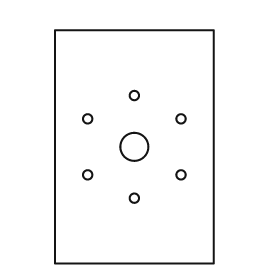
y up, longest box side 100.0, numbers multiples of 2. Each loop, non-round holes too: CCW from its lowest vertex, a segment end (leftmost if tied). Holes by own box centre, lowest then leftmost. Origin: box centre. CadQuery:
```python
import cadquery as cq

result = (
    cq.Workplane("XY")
    .moveTo(-34.0, -50.0)
    .lineTo(34.0, -50.0)
    .lineTo(34.0, 50.0)
    .lineTo(-34.0, 50.0)
    .close()
    .moveTo(0.0, -22.0)
    .circle(2.0)
    .moveTo(-20.0, -12.0)
    .circle(2.0)
    .moveTo(20.0, -12.0)
    .circle(2.0)
    .moveTo(0.0, 0.0)
    .circle(6.0)
    .moveTo(-20.0, 12.0)
    .circle(2.0)
    .moveTo(20.0, 12.0)
    .circle(2.0)
    .moveTo(0.0, 22.0)
    .circle(2.0)
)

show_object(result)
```